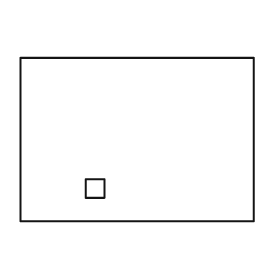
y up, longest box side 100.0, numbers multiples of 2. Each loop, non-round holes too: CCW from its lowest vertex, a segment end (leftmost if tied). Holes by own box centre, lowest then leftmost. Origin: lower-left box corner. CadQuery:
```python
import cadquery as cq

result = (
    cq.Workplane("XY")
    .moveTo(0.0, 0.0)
    .lineTo(100.0, 0.0)
    .lineTo(100.0, 70.0)
    .lineTo(0.0, 70.0)
    .close()
    .moveTo(28.0, 10.0)
    .lineTo(36.0, 10.0)
    .lineTo(36.0, 18.0)
    .lineTo(28.0, 18.0)
    .close()
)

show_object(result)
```